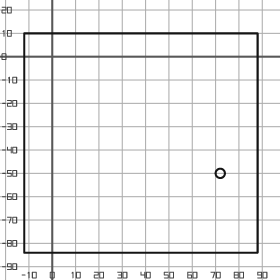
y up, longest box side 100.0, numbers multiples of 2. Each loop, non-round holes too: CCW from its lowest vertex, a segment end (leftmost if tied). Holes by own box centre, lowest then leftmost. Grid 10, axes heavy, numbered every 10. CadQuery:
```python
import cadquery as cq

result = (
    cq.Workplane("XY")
    .moveTo(-12.0, -84.0)
    .lineTo(88.0, -84.0)
    .lineTo(88.0, 10.0)
    .lineTo(-12.0, 10.0)
    .close()
    .moveTo(72.0, -50.0)
    .circle(2.0)
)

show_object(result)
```